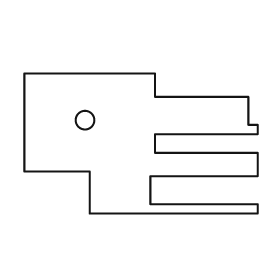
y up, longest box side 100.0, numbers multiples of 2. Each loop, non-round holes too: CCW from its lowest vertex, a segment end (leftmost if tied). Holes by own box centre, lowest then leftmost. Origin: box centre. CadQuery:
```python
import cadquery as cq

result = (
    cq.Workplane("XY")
    .moveTo(-22.0, -30.0)
    .lineTo(50.0, -30.0)
    .lineTo(50.0, -26.0)
    .lineTo(4.0, -26.0)
    .lineTo(4.0, -14.0)
    .lineTo(50.0, -14.0)
    .lineTo(50.0, -4.0)
    .lineTo(6.0, -4.0)
    .lineTo(6.0, 4.0)
    .lineTo(50.0, 4.0)
    .lineTo(50.0, 8.0)
    .lineTo(46.0, 8.0)
    .lineTo(46.0, 20.0)
    .lineTo(6.0, 20.0)
    .lineTo(6.0, 30.0)
    .lineTo(-50.0, 30.0)
    .lineTo(-50.0, -12.0)
    .lineTo(-22.0, -12.0)
    .close()
    .moveTo(-24.0, 10.0)
    .circle(4.0)
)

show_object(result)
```